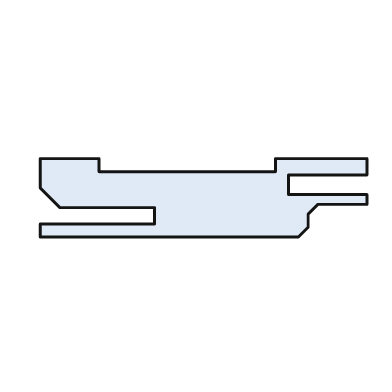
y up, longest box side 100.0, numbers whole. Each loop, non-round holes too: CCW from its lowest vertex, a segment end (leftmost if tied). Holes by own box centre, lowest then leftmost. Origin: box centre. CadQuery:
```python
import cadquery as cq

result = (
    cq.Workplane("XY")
    .moveTo(-50.0, -12.0)
    .lineTo(29.0, -12.0)
    .lineTo(32.0, -9.0)
    .lineTo(32.0, -5.0)
    .lineTo(35.0, -2.0)
    .lineTo(50.0, -2.0)
    .lineTo(50.0, 1.0)
    .lineTo(26.0, 1.0)
    .lineTo(26.0, 7.0)
    .lineTo(50.0, 7.0)
    .lineTo(50.0, 12.0)
    .lineTo(22.0, 12.0)
    .lineTo(22.0, 8.0)
    .lineTo(-32.0, 8.0)
    .lineTo(-32.0, 12.0)
    .lineTo(-50.0, 12.0)
    .lineTo(-50.0, 3.0)
    .lineTo(-44.0, -3.0)
    .lineTo(-15.0, -3.0)
    .lineTo(-15.0, -8.0)
    .lineTo(-50.0, -8.0)
    .close()
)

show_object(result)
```